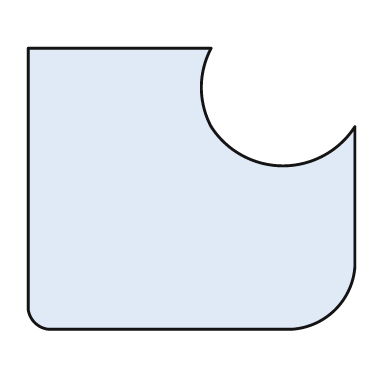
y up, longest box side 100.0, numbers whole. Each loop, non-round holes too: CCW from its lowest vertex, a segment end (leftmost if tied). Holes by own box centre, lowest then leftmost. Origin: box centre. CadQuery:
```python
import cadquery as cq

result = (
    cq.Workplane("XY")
    .moveTo(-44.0, -43.0)
    .lineTo(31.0, -43.0)
    .threePointArc((44.0, -37.0), (50.0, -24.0))
    .lineTo(50.0, 19.0)
    .threePointArc((28.0, 7.0), (6.0, 19.0))
    .threePointArc((3.0, 31.0), (6.0, 43.0))
    .lineTo(-50.0, 43.0)
    .lineTo(-50.0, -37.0)
    .threePointArc((-48.0, -41.0), (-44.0, -43.0))
    .close()
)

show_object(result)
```